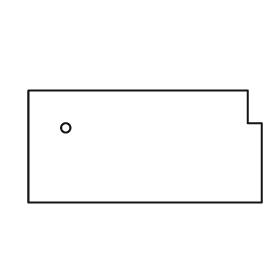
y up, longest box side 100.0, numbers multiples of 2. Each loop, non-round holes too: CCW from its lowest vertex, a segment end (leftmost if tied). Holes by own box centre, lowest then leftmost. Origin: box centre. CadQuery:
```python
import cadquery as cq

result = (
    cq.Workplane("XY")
    .moveTo(-50.0, -24.0)
    .lineTo(50.0, -24.0)
    .lineTo(50.0, 10.0)
    .lineTo(44.0, 10.0)
    .lineTo(44.0, 24.0)
    .lineTo(-50.0, 24.0)
    .close()
    .moveTo(-34.0, 8.0)
    .circle(2.0)
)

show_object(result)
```